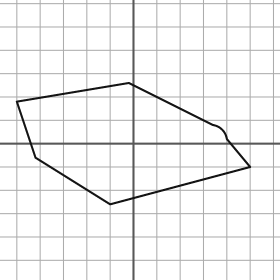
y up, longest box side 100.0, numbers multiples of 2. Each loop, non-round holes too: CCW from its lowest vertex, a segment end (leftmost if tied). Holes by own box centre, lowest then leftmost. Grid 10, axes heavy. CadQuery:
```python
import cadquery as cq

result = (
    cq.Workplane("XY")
    .moveTo(-10.0, -26.0)
    .lineTo(50.0, -10.0)
    .lineTo(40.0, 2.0)
    .threePointArc((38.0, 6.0), (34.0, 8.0))
    .lineTo(-2.0, 26.0)
    .lineTo(-50.0, 18.0)
    .lineTo(-42.0, -6.0)
    .close()
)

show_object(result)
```